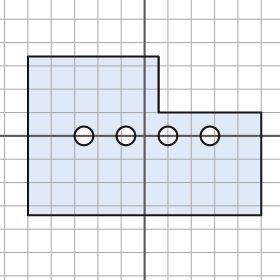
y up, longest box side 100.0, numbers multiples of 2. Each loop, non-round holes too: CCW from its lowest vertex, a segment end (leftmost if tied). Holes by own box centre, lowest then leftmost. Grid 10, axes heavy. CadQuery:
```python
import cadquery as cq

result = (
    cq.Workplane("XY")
    .moveTo(-50.0, -34.0)
    .lineTo(50.0, -34.0)
    .lineTo(50.0, 10.0)
    .lineTo(6.0, 10.0)
    .lineTo(6.0, 34.0)
    .lineTo(-50.0, 34.0)
    .close()
    .moveTo(-26.0, 0.0)
    .circle(4.0)
    .moveTo(-8.0, 0.0)
    .circle(4.0)
    .moveTo(10.0, 0.0)
    .circle(4.0)
    .moveTo(28.0, 0.0)
    .circle(4.0)
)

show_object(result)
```